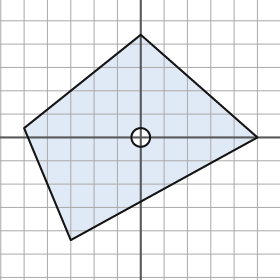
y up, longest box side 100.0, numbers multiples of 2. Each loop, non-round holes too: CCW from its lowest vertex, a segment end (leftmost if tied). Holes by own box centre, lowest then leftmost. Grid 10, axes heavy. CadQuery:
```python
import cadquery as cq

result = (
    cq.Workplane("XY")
    .moveTo(-30.0, -44.0)
    .lineTo(50.0, 0.0)
    .lineTo(0.0, 44.0)
    .lineTo(-50.0, 4.0)
    .close()
    .moveTo(0.0, 0.0)
    .circle(4.0)
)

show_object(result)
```